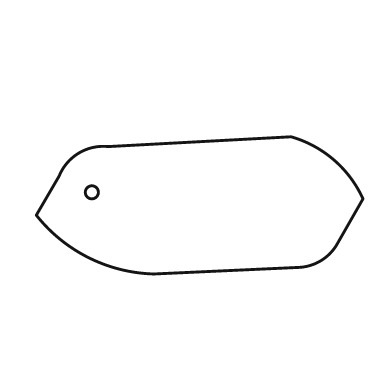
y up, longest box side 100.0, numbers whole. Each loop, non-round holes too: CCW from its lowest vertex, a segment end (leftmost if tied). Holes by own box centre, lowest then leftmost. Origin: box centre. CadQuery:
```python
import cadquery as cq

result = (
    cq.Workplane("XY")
    .moveTo(-14.0, -21.0)
    .lineTo(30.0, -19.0)
    .threePointArc((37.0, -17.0), (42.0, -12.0))
    .lineTo(50.0, 2.0)
    .threePointArc((41.0, 14.0), (28.0, 21.0))
    .lineTo(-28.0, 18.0)
    .threePointArc((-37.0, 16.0), (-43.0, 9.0))
    .lineTo(-50.0, -3.0)
    .threePointArc((-34.0, -16.0), (-14.0, -21.0))
    .close()
    .moveTo(-33.0, 4.0)
    .circle(2.0)
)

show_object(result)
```